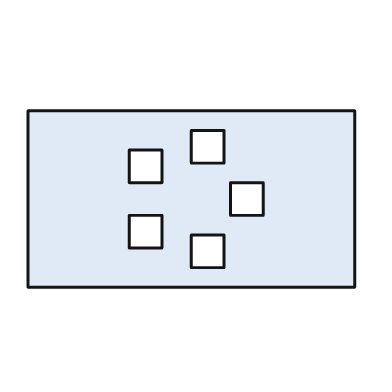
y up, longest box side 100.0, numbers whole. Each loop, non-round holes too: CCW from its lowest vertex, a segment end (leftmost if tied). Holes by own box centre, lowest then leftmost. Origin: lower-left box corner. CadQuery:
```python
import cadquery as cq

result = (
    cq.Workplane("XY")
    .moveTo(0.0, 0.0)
    .lineTo(100.0, 0.0)
    .lineTo(100.0, 54.0)
    .lineTo(0.0, 54.0)
    .close()
    .moveTo(50.0, 6.0)
    .lineTo(60.0, 6.0)
    .lineTo(60.0, 16.0)
    .lineTo(50.0, 16.0)
    .close()
    .moveTo(31.0, 12.0)
    .lineTo(41.0, 12.0)
    .lineTo(41.0, 22.0)
    .lineTo(31.0, 22.0)
    .close()
    .moveTo(62.0, 22.0)
    .lineTo(72.0, 22.0)
    .lineTo(72.0, 32.0)
    .lineTo(62.0, 32.0)
    .close()
    .moveTo(31.0, 32.0)
    .lineTo(41.0, 32.0)
    .lineTo(41.0, 42.0)
    .lineTo(31.0, 42.0)
    .close()
    .moveTo(50.0, 38.0)
    .lineTo(60.0, 38.0)
    .lineTo(60.0, 48.0)
    .lineTo(50.0, 48.0)
    .close()
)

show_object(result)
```